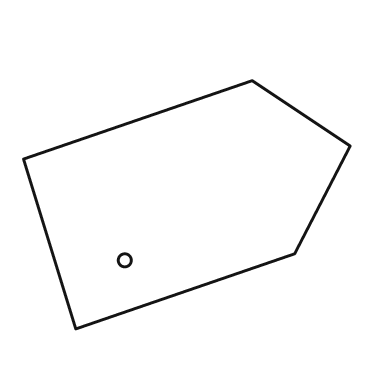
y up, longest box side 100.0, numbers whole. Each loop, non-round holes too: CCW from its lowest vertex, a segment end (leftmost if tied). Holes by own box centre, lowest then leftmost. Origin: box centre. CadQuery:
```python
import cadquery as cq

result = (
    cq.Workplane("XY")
    .moveTo(-34.0, -38.0)
    .lineTo(33.0, -15.0)
    .lineTo(50.0, 18.0)
    .lineTo(20.0, 38.0)
    .lineTo(-50.0, 14.0)
    .close()
    .moveTo(-19.0, -17.0)
    .circle(2.0)
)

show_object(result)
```